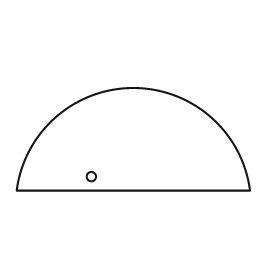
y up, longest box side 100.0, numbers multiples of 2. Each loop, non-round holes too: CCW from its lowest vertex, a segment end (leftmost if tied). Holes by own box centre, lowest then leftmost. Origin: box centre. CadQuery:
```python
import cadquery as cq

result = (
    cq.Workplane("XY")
    .moveTo(-50.0, -22.0)
    .lineTo(50.0, -22.0)
    .threePointArc((0.0, 22.0), (-50.0, -22.0))
    .close()
    .moveTo(-18.0, -16.0)
    .circle(2.0)
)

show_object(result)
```